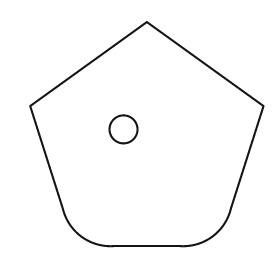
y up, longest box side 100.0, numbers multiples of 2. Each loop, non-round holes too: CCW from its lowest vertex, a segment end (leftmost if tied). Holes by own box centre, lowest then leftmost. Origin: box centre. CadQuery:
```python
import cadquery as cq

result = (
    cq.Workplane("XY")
    .moveTo(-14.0, -48.0)
    .lineTo(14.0, -48.0)
    .threePointArc((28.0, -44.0), (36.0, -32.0))
    .lineTo(50.0, 12.0)
    .lineTo(0.0, 48.0)
    .lineTo(-50.0, 12.0)
    .lineTo(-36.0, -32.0)
    .threePointArc((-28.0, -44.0), (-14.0, -48.0))
    .close()
    .moveTo(-10.0, 2.0)
    .circle(6.0)
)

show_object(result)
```